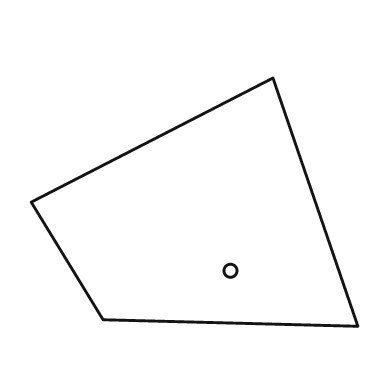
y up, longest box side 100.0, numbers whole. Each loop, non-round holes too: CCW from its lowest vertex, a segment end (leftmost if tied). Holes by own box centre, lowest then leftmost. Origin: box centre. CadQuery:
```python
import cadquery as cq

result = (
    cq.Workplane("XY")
    .moveTo(50.0, -38.0)
    .lineTo(24.0, 38.0)
    .lineTo(-50.0, 0.0)
    .lineTo(-28.0, -36.0)
    .close()
    .moveTo(11.0, -21.0)
    .circle(2.0)
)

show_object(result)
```